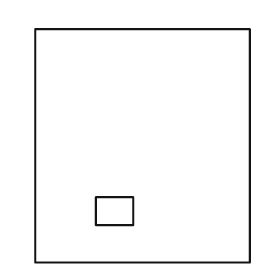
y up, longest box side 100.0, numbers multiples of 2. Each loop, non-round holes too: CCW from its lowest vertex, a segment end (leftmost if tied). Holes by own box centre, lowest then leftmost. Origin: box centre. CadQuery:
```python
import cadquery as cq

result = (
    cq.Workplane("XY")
    .moveTo(-46.0, -50.0)
    .lineTo(46.0, -50.0)
    .lineTo(46.0, 50.0)
    .lineTo(-46.0, 50.0)
    .close()
    .moveTo(-20.0, -34.0)
    .lineTo(-4.0, -34.0)
    .lineTo(-4.0, -22.0)
    .lineTo(-20.0, -22.0)
    .close()
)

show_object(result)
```